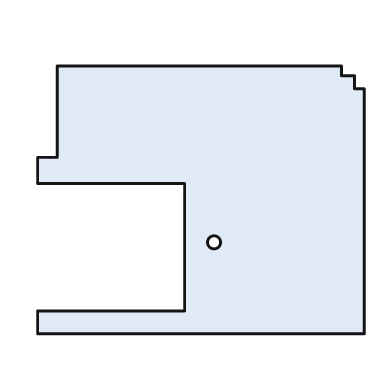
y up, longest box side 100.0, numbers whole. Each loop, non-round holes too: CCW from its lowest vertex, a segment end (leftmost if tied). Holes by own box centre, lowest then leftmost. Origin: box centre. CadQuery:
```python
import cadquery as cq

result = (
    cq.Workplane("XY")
    .moveTo(-50.0, -41.0)
    .lineTo(50.0, -41.0)
    .lineTo(50.0, 34.0)
    .lineTo(47.0, 34.0)
    .lineTo(47.0, 38.0)
    .lineTo(43.0, 38.0)
    .lineTo(43.0, 41.0)
    .lineTo(-44.0, 41.0)
    .lineTo(-44.0, 13.0)
    .lineTo(-50.0, 13.0)
    .lineTo(-50.0, 5.0)
    .lineTo(-5.0, 5.0)
    .lineTo(-5.0, -34.0)
    .lineTo(-50.0, -34.0)
    .close()
    .moveTo(4.0, -13.0)
    .circle(2.0)
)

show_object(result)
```